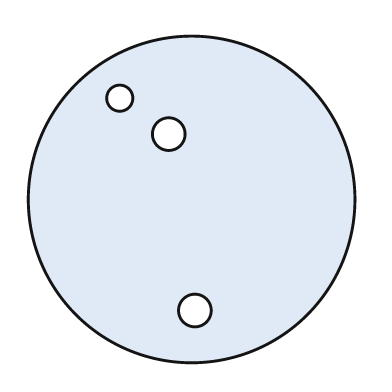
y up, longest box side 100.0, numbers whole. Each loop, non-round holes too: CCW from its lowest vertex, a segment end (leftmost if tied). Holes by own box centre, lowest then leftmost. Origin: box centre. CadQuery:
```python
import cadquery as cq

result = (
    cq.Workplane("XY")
    .moveTo(0.0, 0.0)
    .circle(50.0)
    .moveTo(1.0, -34.0)
    .circle(5.0)
    .moveTo(-7.0, 20.0)
    .circle(5.0)
    .moveTo(-22.0, 31.0)
    .circle(4.0)
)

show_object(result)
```